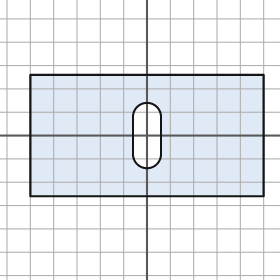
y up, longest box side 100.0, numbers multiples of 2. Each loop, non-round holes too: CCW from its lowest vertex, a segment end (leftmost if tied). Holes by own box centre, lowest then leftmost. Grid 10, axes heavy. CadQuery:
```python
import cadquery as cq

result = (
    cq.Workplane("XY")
    .moveTo(-50.0, -26.0)
    .lineTo(50.0, -26.0)
    .lineTo(50.0, 26.0)
    .lineTo(-50.0, 26.0)
    .close()
    .moveTo(-6.0, -8.0)
    .threePointArc((0.0, -14.0), (6.0, -8.0))
    .lineTo(6.0, 8.0)
    .threePointArc((0.0, 14.0), (-6.0, 8.0))
    .close()
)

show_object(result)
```